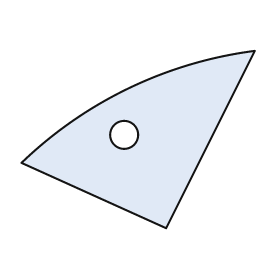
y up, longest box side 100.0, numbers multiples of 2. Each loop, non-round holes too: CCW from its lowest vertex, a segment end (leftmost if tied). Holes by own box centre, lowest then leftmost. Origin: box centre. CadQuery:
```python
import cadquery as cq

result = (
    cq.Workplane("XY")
    .moveTo(12.0, -38.0)
    .lineTo(50.0, 38.0)
    .threePointArc((-4.0, 22.0), (-50.0, -10.0))
    .close()
    .moveTo(-6.0, 2.0)
    .circle(6.0)
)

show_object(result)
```